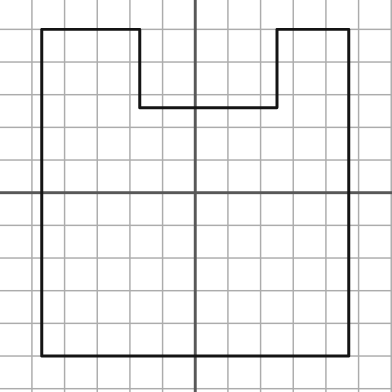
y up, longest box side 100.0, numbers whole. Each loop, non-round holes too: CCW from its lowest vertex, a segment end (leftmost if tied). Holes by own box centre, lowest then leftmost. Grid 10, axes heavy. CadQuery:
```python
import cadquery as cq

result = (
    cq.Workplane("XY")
    .moveTo(-47.0, -50.0)
    .lineTo(47.0, -50.0)
    .lineTo(47.0, 50.0)
    .lineTo(25.0, 50.0)
    .lineTo(25.0, 26.0)
    .lineTo(-17.0, 26.0)
    .lineTo(-17.0, 50.0)
    .lineTo(-47.0, 50.0)
    .close()
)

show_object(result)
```